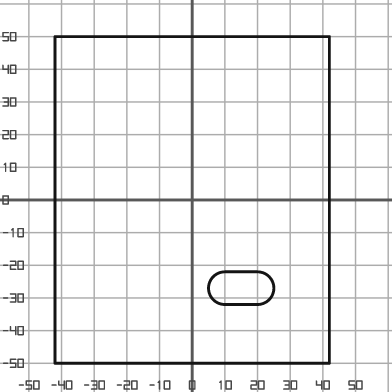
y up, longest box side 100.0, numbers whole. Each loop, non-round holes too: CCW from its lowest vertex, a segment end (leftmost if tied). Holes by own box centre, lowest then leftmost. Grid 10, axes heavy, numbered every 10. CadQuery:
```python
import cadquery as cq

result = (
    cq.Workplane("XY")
    .moveTo(-42.0, -50.0)
    .lineTo(42.0, -50.0)
    .lineTo(42.0, 50.0)
    .lineTo(-42.0, 50.0)
    .close()
    .moveTo(10.0, -32.0)
    .lineTo(20.0, -32.0)
    .threePointArc((25.0, -27.0), (20.0, -22.0))
    .lineTo(10.0, -22.0)
    .threePointArc((5.0, -27.0), (10.0, -32.0))
    .close()
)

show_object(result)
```